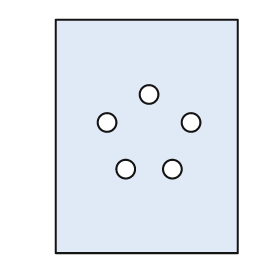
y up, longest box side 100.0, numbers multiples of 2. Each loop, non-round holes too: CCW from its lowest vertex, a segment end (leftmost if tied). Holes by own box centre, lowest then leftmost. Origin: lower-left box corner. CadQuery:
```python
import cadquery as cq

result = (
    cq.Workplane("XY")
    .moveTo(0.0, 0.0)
    .lineTo(78.0, 0.0)
    .lineTo(78.0, 100.0)
    .lineTo(0.0, 100.0)
    .close()
    .moveTo(30.0, 36.0)
    .circle(4.0)
    .moveTo(50.0, 36.0)
    .circle(4.0)
    .moveTo(22.0, 56.0)
    .circle(4.0)
    .moveTo(58.0, 56.0)
    .circle(4.0)
    .moveTo(40.0, 68.0)
    .circle(4.0)
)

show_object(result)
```